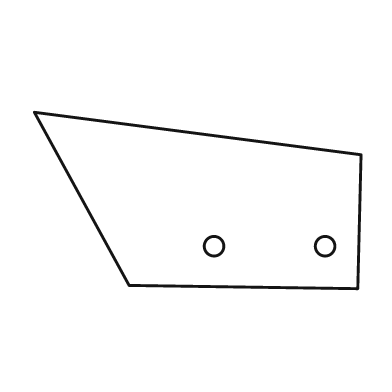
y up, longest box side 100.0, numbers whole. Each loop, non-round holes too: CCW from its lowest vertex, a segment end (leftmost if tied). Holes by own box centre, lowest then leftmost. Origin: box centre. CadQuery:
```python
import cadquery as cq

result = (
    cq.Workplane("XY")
    .moveTo(49.0, -27.0)
    .lineTo(50.0, 14.0)
    .lineTo(-50.0, 27.0)
    .lineTo(-21.0, -26.0)
    .close()
    .moveTo(5.0, -14.0)
    .circle(3.0)
    .moveTo(39.0, -14.0)
    .circle(3.0)
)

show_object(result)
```